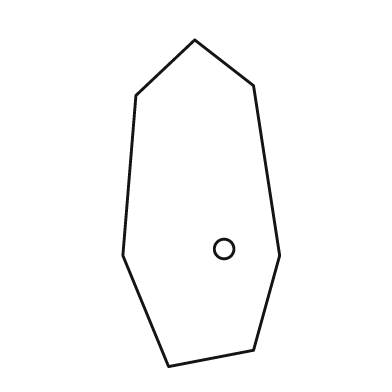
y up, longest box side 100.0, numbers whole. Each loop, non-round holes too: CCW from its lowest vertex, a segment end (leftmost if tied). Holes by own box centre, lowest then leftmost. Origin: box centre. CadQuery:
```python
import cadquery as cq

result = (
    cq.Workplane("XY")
    .moveTo(-10.0, -50.0)
    .lineTo(16.0, -45.0)
    .lineTo(24.0, -16.0)
    .lineTo(16.0, 36.0)
    .lineTo(-2.0, 50.0)
    .lineTo(-20.0, 33.0)
    .lineTo(-24.0, -16.0)
    .close()
    .moveTo(7.0, -14.0)
    .circle(3.0)
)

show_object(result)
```